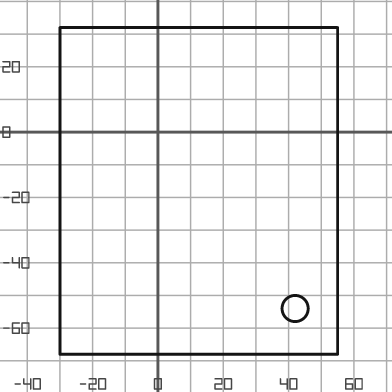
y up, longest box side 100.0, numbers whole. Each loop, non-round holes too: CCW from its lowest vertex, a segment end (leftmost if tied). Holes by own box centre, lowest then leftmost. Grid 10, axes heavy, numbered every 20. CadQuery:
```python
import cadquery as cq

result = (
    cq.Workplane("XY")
    .moveTo(-30.0, -68.0)
    .lineTo(55.0, -68.0)
    .lineTo(55.0, 32.0)
    .lineTo(-30.0, 32.0)
    .close()
    .moveTo(42.0, -54.0)
    .circle(4.0)
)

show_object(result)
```